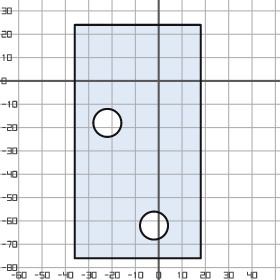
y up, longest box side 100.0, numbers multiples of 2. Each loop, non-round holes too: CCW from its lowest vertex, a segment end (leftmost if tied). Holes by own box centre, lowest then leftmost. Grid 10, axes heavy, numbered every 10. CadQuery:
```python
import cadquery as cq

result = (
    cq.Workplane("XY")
    .moveTo(-36.0, -76.0)
    .lineTo(18.0, -76.0)
    .lineTo(18.0, 24.0)
    .lineTo(-36.0, 24.0)
    .close()
    .moveTo(-2.0, -62.0)
    .circle(6.0)
    .moveTo(-22.0, -18.0)
    .circle(6.0)
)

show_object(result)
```